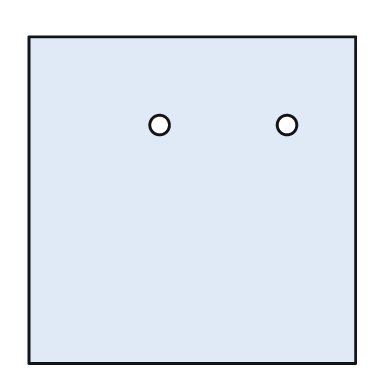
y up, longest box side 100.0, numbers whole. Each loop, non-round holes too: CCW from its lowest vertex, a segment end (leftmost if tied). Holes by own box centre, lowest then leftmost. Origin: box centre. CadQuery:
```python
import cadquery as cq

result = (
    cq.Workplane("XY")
    .moveTo(-50.0, -50.0)
    .lineTo(50.0, -50.0)
    .lineTo(50.0, 50.0)
    .lineTo(-50.0, 50.0)
    .close()
    .moveTo(-10.0, 23.0)
    .circle(3.0)
    .moveTo(29.0, 23.0)
    .circle(3.0)
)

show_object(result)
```